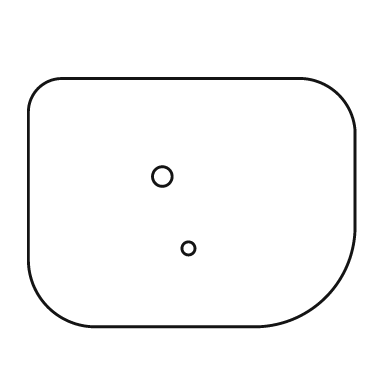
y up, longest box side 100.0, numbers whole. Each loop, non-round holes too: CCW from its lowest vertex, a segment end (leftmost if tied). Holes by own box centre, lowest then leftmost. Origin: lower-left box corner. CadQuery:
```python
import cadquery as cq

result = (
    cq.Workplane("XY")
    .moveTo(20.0, 0.0)
    .lineTo(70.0, 0.0)
    .threePointArc((91.0, 9.0), (100.0, 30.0))
    .lineTo(100.0, 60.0)
    .threePointArc((95.0, 71.0), (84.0, 76.0))
    .lineTo(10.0, 76.0)
    .threePointArc((3.0, 73.0), (0.0, 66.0))
    .lineTo(0.0, 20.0)
    .threePointArc((6.0, 6.0), (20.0, 0.0))
    .close()
    .moveTo(49.0, 24.0)
    .circle(2.0)
    .moveTo(41.0, 46.0)
    .circle(3.0)
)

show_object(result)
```